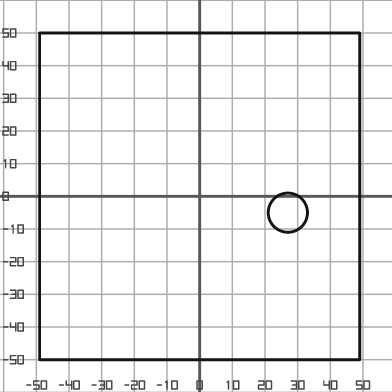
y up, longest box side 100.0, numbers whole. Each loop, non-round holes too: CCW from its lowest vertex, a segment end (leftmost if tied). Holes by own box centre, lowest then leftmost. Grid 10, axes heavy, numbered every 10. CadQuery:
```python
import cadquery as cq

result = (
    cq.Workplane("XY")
    .moveTo(-49.0, -50.0)
    .lineTo(49.0, -50.0)
    .lineTo(49.0, 50.0)
    .lineTo(-49.0, 50.0)
    .close()
    .moveTo(27.0, -5.0)
    .circle(6.0)
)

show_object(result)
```